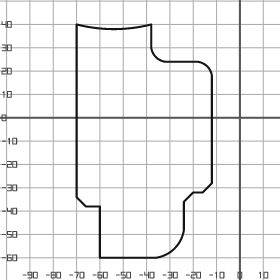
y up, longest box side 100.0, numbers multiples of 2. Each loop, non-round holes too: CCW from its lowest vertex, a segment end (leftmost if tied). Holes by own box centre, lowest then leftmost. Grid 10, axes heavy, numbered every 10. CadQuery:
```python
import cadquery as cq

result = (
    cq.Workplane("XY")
    .moveTo(-60.0, -60.0)
    .lineTo(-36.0, -60.0)
    .threePointArc((-28.0, -56.0), (-24.0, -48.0))
    .lineTo(-24.0, -36.0)
    .lineTo(-20.0, -32.0)
    .lineTo(-16.0, -32.0)
    .lineTo(-12.0, -28.0)
    .lineTo(-12.0, 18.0)
    .threePointArc((-14.0, 22.0), (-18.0, 24.0))
    .lineTo(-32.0, 24.0)
    .threePointArc((-36.0, 26.0), (-38.0, 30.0))
    .lineTo(-38.0, 40.0)
    .threePointArc((-54.0, 38.0), (-70.0, 40.0))
    .lineTo(-70.0, -34.0)
    .lineTo(-66.0, -38.0)
    .lineTo(-60.0, -38.0)
    .close()
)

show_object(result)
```